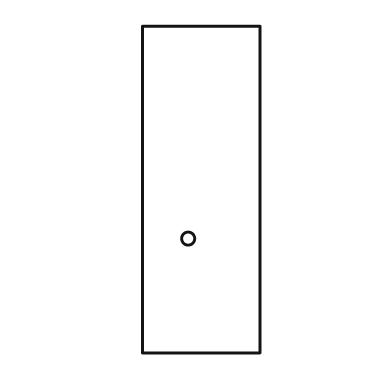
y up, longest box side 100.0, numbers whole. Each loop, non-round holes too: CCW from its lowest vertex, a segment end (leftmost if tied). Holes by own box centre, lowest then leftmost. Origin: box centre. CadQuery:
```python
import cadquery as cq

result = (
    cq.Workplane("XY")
    .moveTo(-18.0, -50.0)
    .lineTo(18.0, -50.0)
    .lineTo(18.0, 50.0)
    .lineTo(-18.0, 50.0)
    .close()
    .moveTo(-4.0, -15.0)
    .circle(2.0)
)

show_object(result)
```